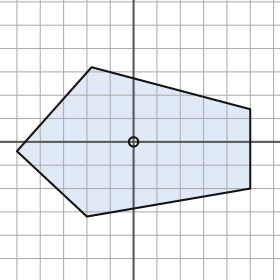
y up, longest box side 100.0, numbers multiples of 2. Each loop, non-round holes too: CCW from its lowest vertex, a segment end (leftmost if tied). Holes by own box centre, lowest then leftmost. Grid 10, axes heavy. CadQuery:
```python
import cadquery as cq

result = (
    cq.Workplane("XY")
    .moveTo(-20.0, -32.0)
    .lineTo(50.0, -20.0)
    .lineTo(50.0, 14.0)
    .lineTo(-18.0, 32.0)
    .lineTo(-50.0, -4.0)
    .close()
    .moveTo(0.0, 0.0)
    .circle(2.0)
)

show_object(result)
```